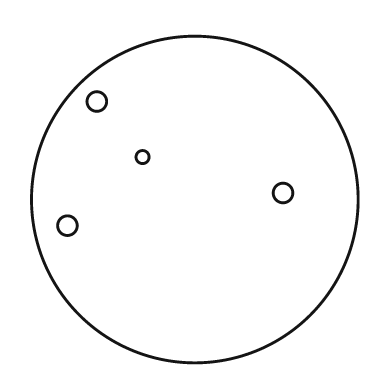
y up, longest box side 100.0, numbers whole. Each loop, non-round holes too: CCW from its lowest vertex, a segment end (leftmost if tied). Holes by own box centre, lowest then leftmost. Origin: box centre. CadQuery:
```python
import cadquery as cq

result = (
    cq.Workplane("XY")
    .moveTo(0.0, 0.0)
    .circle(50.0)
    .moveTo(-39.0, -8.0)
    .circle(3.0)
    .moveTo(27.0, 2.0)
    .circle(3.0)
    .moveTo(-16.0, 13.0)
    .circle(2.0)
    .moveTo(-30.0, 30.0)
    .circle(3.0)
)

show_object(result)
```